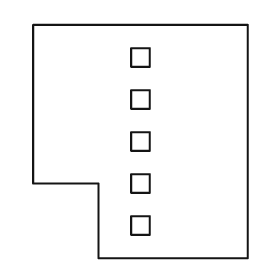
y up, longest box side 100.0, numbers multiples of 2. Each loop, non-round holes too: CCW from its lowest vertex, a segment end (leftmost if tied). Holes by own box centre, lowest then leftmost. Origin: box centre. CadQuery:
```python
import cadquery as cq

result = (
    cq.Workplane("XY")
    .moveTo(-18.0, -50.0)
    .lineTo(46.0, -50.0)
    .lineTo(46.0, 50.0)
    .lineTo(-46.0, 50.0)
    .lineTo(-46.0, -18.0)
    .lineTo(-18.0, -18.0)
    .close()
    .moveTo(-4.0, -40.0)
    .lineTo(4.0, -40.0)
    .lineTo(4.0, -32.0)
    .lineTo(-4.0, -32.0)
    .close()
    .moveTo(-4.0, -22.0)
    .lineTo(4.0, -22.0)
    .lineTo(4.0, -14.0)
    .lineTo(-4.0, -14.0)
    .close()
    .moveTo(-4.0, -4.0)
    .lineTo(4.0, -4.0)
    .lineTo(4.0, 4.0)
    .lineTo(-4.0, 4.0)
    .close()
    .moveTo(-4.0, 14.0)
    .lineTo(4.0, 14.0)
    .lineTo(4.0, 22.0)
    .lineTo(-4.0, 22.0)
    .close()
    .moveTo(-4.0, 32.0)
    .lineTo(4.0, 32.0)
    .lineTo(4.0, 40.0)
    .lineTo(-4.0, 40.0)
    .close()
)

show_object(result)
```